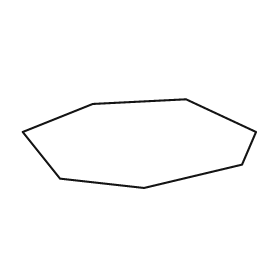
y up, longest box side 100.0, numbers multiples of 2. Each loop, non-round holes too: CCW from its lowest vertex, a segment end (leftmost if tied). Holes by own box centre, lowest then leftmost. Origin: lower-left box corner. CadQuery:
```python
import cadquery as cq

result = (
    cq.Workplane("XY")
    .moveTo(52.0, 0.0)
    .lineTo(94.0, 10.0)
    .lineTo(100.0, 24.0)
    .lineTo(70.0, 38.0)
    .lineTo(30.0, 36.0)
    .lineTo(0.0, 24.0)
    .lineTo(16.0, 4.0)
    .close()
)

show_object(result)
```